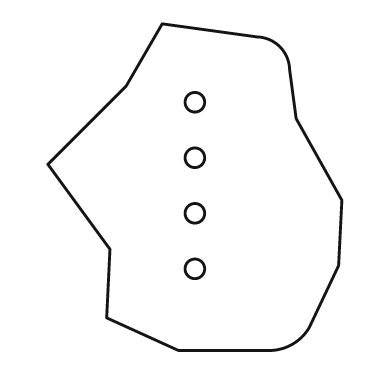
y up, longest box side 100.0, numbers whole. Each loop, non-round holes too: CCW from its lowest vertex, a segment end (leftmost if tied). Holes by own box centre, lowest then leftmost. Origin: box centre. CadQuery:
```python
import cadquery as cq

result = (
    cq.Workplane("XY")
    .moveTo(-5.0, -50.0)
    .lineTo(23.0, -50.0)
    .threePointArc((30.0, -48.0), (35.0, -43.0))
    .lineTo(44.0, -24.0)
    .lineTo(45.0, -4.0)
    .lineTo(31.0, 21.0)
    .lineTo(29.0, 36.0)
    .threePointArc((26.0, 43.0), (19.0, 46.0))
    .lineTo(-10.0, 50.0)
    .lineTo(-21.0, 31.0)
    .lineTo(-45.0, 7.0)
    .lineTo(-26.0, -19.0)
    .lineTo(-27.0, -40.0)
    .close()
    .moveTo(0.0, -25.0)
    .circle(3.0)
    .moveTo(0.0, -8.0)
    .circle(3.0)
    .moveTo(0.0, 9.0)
    .circle(3.0)
    .moveTo(0.0, 26.0)
    .circle(3.0)
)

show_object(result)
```